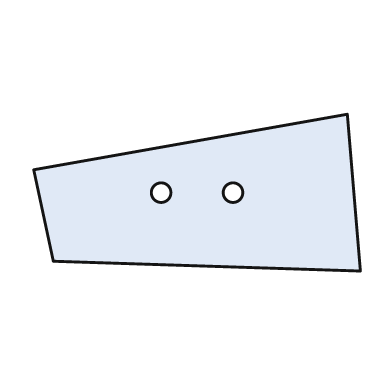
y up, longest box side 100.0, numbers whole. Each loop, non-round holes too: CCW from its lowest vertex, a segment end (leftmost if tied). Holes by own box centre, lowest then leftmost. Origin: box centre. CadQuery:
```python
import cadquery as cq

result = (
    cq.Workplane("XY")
    .moveTo(50.0, -24.0)
    .lineTo(46.0, 24.0)
    .lineTo(-50.0, 7.0)
    .lineTo(-44.0, -21.0)
    .close()
    .moveTo(-11.0, 0.0)
    .circle(3.0)
    .moveTo(11.0, 0.0)
    .circle(3.0)
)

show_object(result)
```